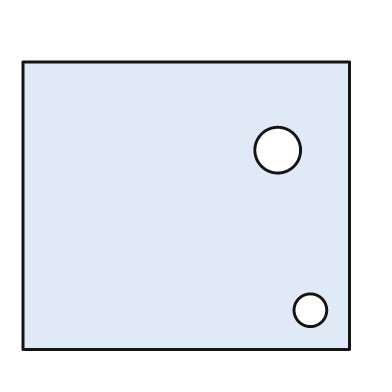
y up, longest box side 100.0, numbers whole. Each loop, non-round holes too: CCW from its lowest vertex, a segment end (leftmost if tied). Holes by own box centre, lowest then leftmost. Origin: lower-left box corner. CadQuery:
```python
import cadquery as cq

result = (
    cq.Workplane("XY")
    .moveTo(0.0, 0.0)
    .lineTo(100.0, 0.0)
    .lineTo(100.0, 88.0)
    .lineTo(0.0, 88.0)
    .close()
    .moveTo(88.0, 12.0)
    .circle(5.0)
    .moveTo(78.0, 61.0)
    .circle(7.0)
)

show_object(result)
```